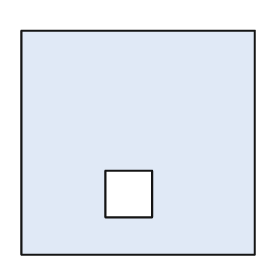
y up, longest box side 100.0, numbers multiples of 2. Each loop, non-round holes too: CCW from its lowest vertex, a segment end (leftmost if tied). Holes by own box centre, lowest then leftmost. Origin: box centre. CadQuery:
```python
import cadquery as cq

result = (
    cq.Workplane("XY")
    .moveTo(-50.0, -48.0)
    .lineTo(50.0, -48.0)
    .lineTo(50.0, 48.0)
    .lineTo(-50.0, 48.0)
    .close()
    .moveTo(-14.0, -32.0)
    .lineTo(6.0, -32.0)
    .lineTo(6.0, -12.0)
    .lineTo(-14.0, -12.0)
    .close()
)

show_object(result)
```